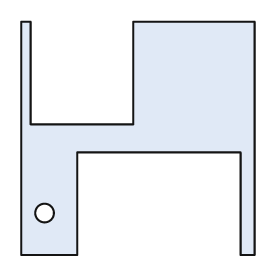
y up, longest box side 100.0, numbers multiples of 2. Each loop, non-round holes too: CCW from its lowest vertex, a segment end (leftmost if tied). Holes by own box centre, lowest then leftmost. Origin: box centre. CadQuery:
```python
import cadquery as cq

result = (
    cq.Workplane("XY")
    .moveTo(-50.0, -50.0)
    .lineTo(-26.0, -50.0)
    .lineTo(-26.0, -6.0)
    .lineTo(44.0, -6.0)
    .lineTo(44.0, -50.0)
    .lineTo(50.0, -50.0)
    .lineTo(50.0, 50.0)
    .lineTo(-2.0, 50.0)
    .lineTo(-2.0, 6.0)
    .lineTo(-46.0, 6.0)
    .lineTo(-46.0, 50.0)
    .lineTo(-50.0, 50.0)
    .close()
    .moveTo(-40.0, -32.0)
    .circle(4.0)
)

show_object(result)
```